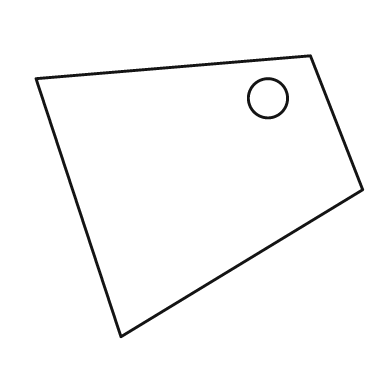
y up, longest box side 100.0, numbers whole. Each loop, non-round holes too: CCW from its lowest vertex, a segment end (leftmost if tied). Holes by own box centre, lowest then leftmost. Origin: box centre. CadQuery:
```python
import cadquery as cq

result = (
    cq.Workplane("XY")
    .moveTo(-24.0, -43.0)
    .lineTo(50.0, 2.0)
    .lineTo(34.0, 43.0)
    .lineTo(-50.0, 36.0)
    .close()
    .moveTo(21.0, 30.0)
    .circle(6.0)
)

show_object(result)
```